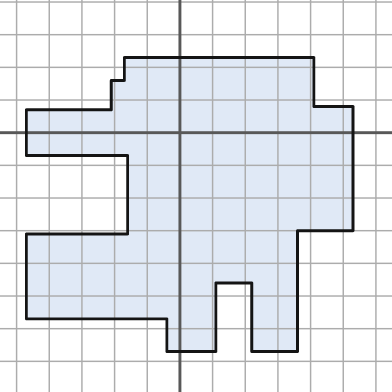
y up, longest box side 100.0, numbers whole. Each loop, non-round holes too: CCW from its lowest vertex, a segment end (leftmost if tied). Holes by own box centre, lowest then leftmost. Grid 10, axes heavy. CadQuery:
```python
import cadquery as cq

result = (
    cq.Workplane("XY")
    .moveTo(-4.0, -67.0)
    .lineTo(11.0, -67.0)
    .lineTo(11.0, -46.0)
    .lineTo(22.0, -46.0)
    .lineTo(22.0, -67.0)
    .lineTo(36.0, -67.0)
    .lineTo(36.0, -30.0)
    .lineTo(53.0, -30.0)
    .lineTo(53.0, 8.0)
    .lineTo(41.0, 8.0)
    .lineTo(41.0, 23.0)
    .lineTo(-17.0, 23.0)
    .lineTo(-17.0, 16.0)
    .lineTo(-21.0, 16.0)
    .lineTo(-21.0, 7.0)
    .lineTo(-47.0, 7.0)
    .lineTo(-47.0, -7.0)
    .lineTo(-16.0, -7.0)
    .lineTo(-16.0, -31.0)
    .lineTo(-47.0, -31.0)
    .lineTo(-47.0, -57.0)
    .lineTo(-4.0, -57.0)
    .close()
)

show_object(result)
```